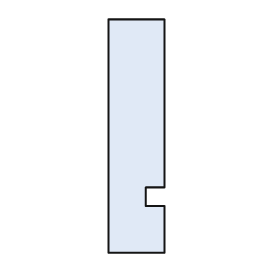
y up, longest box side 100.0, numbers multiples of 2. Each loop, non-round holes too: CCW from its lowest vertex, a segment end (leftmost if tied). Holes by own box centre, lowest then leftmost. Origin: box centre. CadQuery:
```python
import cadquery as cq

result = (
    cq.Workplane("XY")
    .moveTo(-12.0, -50.0)
    .lineTo(12.0, -50.0)
    .lineTo(12.0, -30.0)
    .lineTo(4.0, -30.0)
    .lineTo(4.0, -22.0)
    .lineTo(12.0, -22.0)
    .lineTo(12.0, 50.0)
    .lineTo(-12.0, 50.0)
    .close()
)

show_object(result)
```